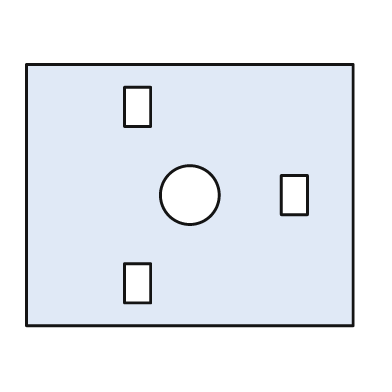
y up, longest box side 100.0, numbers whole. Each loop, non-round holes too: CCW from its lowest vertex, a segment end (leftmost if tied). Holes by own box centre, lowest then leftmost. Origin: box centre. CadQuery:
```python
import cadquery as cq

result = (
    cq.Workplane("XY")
    .moveTo(-50.0, -40.0)
    .lineTo(50.0, -40.0)
    .lineTo(50.0, 40.0)
    .lineTo(-50.0, 40.0)
    .close()
    .moveTo(-20.0, -33.0)
    .lineTo(-12.0, -33.0)
    .lineTo(-12.0, -21.0)
    .lineTo(-20.0, -21.0)
    .close()
    .moveTo(0.0, 0.0)
    .circle(9.0)
    .moveTo(28.0, -6.0)
    .lineTo(36.0, -6.0)
    .lineTo(36.0, 6.0)
    .lineTo(28.0, 6.0)
    .close()
    .moveTo(-20.0, 21.0)
    .lineTo(-12.0, 21.0)
    .lineTo(-12.0, 33.0)
    .lineTo(-20.0, 33.0)
    .close()
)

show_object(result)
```